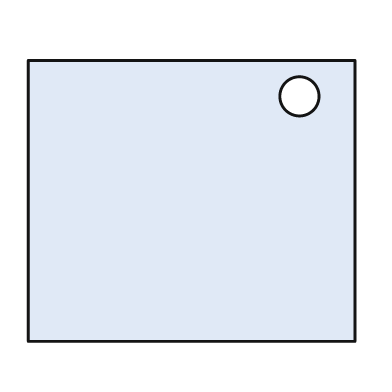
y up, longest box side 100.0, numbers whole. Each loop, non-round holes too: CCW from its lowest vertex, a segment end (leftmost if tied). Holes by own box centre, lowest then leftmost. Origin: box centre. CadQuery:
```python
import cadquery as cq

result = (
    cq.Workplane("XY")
    .moveTo(-50.0, -43.0)
    .lineTo(50.0, -43.0)
    .lineTo(50.0, 43.0)
    .lineTo(-50.0, 43.0)
    .close()
    .moveTo(33.0, 32.0)
    .circle(6.0)
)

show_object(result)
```